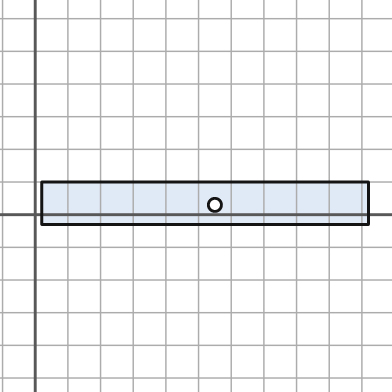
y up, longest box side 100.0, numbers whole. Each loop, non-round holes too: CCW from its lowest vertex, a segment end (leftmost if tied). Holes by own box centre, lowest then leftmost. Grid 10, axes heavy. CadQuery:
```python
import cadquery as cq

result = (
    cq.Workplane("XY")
    .moveTo(2.0, -3.0)
    .lineTo(102.0, -3.0)
    .lineTo(102.0, 10.0)
    .lineTo(2.0, 10.0)
    .close()
    .moveTo(55.0, 3.0)
    .circle(2.0)
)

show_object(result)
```